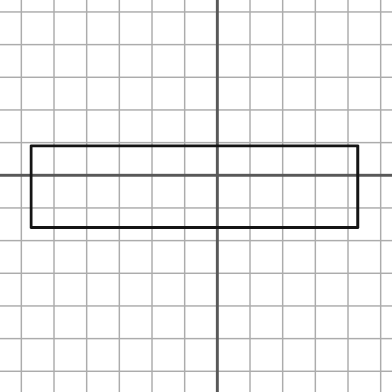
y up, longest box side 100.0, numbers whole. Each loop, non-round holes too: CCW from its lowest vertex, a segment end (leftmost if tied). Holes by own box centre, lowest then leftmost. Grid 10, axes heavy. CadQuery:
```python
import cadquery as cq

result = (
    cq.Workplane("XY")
    .moveTo(-57.0, -16.0)
    .lineTo(43.0, -16.0)
    .lineTo(43.0, 9.0)
    .lineTo(-57.0, 9.0)
    .close()
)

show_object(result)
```